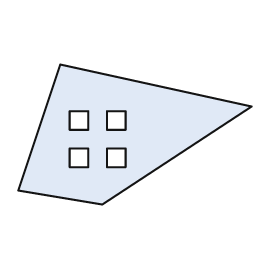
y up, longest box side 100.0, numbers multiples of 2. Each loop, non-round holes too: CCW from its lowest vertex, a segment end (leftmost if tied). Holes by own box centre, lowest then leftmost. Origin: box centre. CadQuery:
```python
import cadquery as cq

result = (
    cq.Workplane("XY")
    .moveTo(-14.0, -30.0)
    .lineTo(50.0, 12.0)
    .lineTo(-32.0, 30.0)
    .lineTo(-50.0, -24.0)
    .close()
    .moveTo(-28.0, -14.0)
    .lineTo(-20.0, -14.0)
    .lineTo(-20.0, -6.0)
    .lineTo(-28.0, -6.0)
    .close()
    .moveTo(-12.0, -14.0)
    .lineTo(-4.0, -14.0)
    .lineTo(-4.0, -6.0)
    .lineTo(-12.0, -6.0)
    .close()
    .moveTo(-28.0, 2.0)
    .lineTo(-20.0, 2.0)
    .lineTo(-20.0, 10.0)
    .lineTo(-28.0, 10.0)
    .close()
    .moveTo(-12.0, 2.0)
    .lineTo(-4.0, 2.0)
    .lineTo(-4.0, 10.0)
    .lineTo(-12.0, 10.0)
    .close()
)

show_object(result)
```